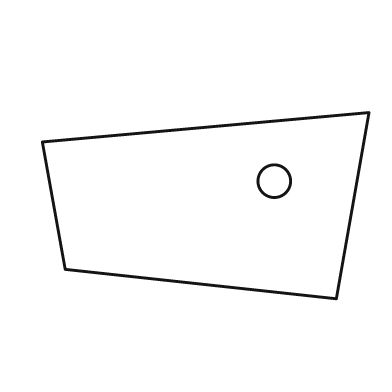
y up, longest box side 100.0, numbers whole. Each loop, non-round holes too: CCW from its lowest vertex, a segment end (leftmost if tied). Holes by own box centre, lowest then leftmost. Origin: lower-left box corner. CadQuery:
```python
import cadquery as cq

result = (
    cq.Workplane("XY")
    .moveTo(90.0, 0.0)
    .lineTo(100.0, 57.0)
    .lineTo(0.0, 48.0)
    .lineTo(7.0, 9.0)
    .close()
    .moveTo(71.0, 36.0)
    .circle(5.0)
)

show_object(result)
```